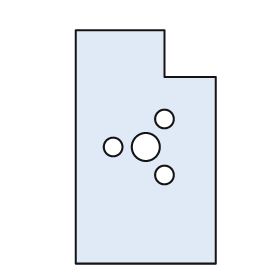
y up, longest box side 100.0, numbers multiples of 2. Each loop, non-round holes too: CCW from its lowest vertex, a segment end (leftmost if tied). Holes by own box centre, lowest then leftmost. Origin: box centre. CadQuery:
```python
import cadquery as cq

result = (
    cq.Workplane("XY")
    .moveTo(-30.0, -50.0)
    .lineTo(30.0, -50.0)
    .lineTo(30.0, 30.0)
    .lineTo(8.0, 30.0)
    .lineTo(8.0, 50.0)
    .lineTo(-30.0, 50.0)
    .close()
    .moveTo(8.0, -12.0)
    .circle(4.0)
    .moveTo(-14.0, 0.0)
    .circle(4.0)
    .moveTo(0.0, 0.0)
    .circle(6.0)
    .moveTo(8.0, 12.0)
    .circle(4.0)
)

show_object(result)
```